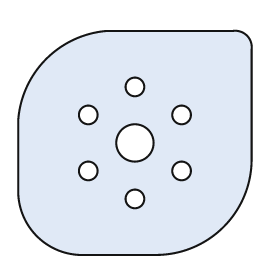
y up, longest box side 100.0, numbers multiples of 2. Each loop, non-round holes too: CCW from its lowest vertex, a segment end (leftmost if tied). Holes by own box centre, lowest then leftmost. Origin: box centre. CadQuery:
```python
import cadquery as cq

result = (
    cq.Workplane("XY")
    .moveTo(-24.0, -48.0)
    .lineTo(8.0, -48.0)
    .threePointArc((38.0, -36.0), (50.0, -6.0))
    .lineTo(50.0, 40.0)
    .threePointArc((48.0, 46.0), (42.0, 48.0))
    .lineTo(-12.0, 48.0)
    .threePointArc((-38.0, 36.0), (-50.0, 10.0))
    .lineTo(-50.0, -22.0)
    .threePointArc((-42.0, -40.0), (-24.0, -48.0))
    .close()
    .moveTo(0.0, -24.0)
    .circle(4.0)
    .moveTo(-20.0, -12.0)
    .circle(4.0)
    .moveTo(20.0, -12.0)
    .circle(4.0)
    .moveTo(0.0, 0.0)
    .circle(8.0)
    .moveTo(-20.0, 12.0)
    .circle(4.0)
    .moveTo(20.0, 12.0)
    .circle(4.0)
    .moveTo(0.0, 24.0)
    .circle(4.0)
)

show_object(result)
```